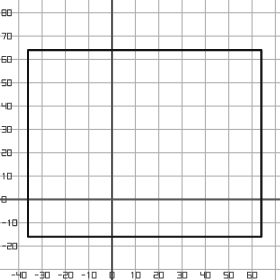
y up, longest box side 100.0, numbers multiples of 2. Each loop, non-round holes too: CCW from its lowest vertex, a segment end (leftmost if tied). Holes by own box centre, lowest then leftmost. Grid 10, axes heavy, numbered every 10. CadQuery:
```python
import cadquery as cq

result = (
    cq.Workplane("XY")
    .moveTo(-36.0, -16.0)
    .lineTo(64.0, -16.0)
    .lineTo(64.0, 64.0)
    .lineTo(-36.0, 64.0)
    .close()
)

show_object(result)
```